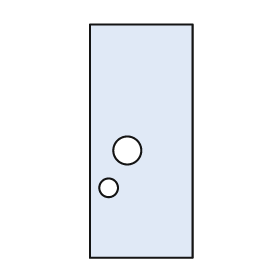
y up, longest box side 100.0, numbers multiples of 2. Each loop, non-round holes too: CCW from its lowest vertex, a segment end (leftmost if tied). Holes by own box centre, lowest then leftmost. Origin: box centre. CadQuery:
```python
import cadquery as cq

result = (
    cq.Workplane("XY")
    .moveTo(-22.0, -50.0)
    .lineTo(22.0, -50.0)
    .lineTo(22.0, 50.0)
    .lineTo(-22.0, 50.0)
    .close()
    .moveTo(-14.0, -20.0)
    .circle(4.0)
    .moveTo(-6.0, -4.0)
    .circle(6.0)
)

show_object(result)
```